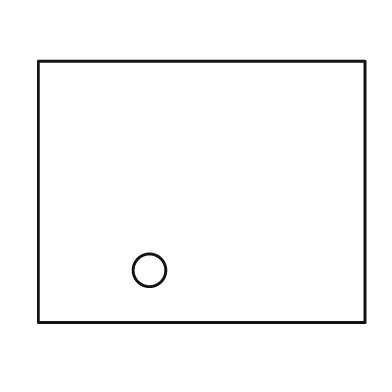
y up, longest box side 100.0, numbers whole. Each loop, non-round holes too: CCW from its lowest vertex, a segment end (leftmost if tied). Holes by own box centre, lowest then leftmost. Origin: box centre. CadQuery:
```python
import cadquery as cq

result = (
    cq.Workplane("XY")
    .moveTo(-50.0, -40.0)
    .lineTo(50.0, -40.0)
    .lineTo(50.0, 40.0)
    .lineTo(-50.0, 40.0)
    .close()
    .moveTo(-16.0, -24.0)
    .circle(5.0)
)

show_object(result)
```